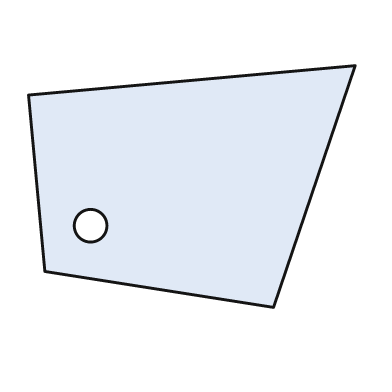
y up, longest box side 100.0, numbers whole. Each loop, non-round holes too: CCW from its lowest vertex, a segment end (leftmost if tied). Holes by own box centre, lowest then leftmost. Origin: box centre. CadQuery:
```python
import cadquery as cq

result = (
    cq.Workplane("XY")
    .moveTo(25.0, -37.0)
    .lineTo(50.0, 37.0)
    .lineTo(-50.0, 28.0)
    .lineTo(-45.0, -26.0)
    .close()
    .moveTo(-31.0, -12.0)
    .circle(5.0)
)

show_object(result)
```